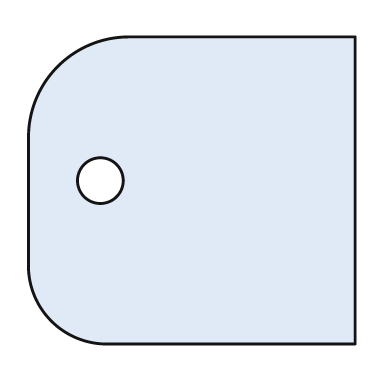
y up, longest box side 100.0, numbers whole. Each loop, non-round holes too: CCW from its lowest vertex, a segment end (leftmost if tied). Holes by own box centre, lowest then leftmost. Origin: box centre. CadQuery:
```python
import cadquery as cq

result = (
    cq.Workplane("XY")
    .moveTo(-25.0, -47.0)
    .lineTo(50.0, -47.0)
    .lineTo(50.0, 47.0)
    .lineTo(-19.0, 47.0)
    .threePointArc((-41.0, 38.0), (-50.0, 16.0))
    .lineTo(-50.0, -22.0)
    .threePointArc((-43.0, -40.0), (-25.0, -47.0))
    .close()
    .moveTo(-28.0, 3.0)
    .circle(7.0)
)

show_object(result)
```